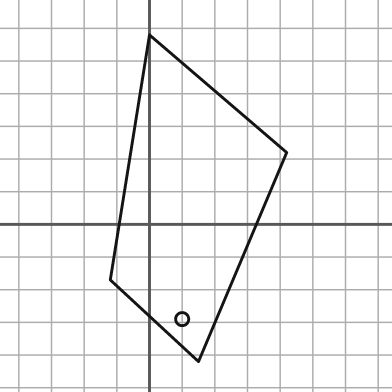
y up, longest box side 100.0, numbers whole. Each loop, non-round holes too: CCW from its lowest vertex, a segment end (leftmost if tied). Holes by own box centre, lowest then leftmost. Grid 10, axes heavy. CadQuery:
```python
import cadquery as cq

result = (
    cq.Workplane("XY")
    .moveTo(15.0, -42.0)
    .lineTo(42.0, 22.0)
    .lineTo(0.0, 58.0)
    .lineTo(-12.0, -17.0)
    .close()
    .moveTo(10.0, -29.0)
    .circle(2.0)
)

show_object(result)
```